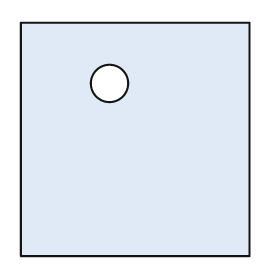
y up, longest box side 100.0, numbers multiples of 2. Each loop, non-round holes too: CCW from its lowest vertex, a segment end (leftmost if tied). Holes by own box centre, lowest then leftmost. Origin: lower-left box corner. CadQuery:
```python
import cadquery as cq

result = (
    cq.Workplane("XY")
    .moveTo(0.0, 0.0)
    .lineTo(98.0, 0.0)
    .lineTo(98.0, 100.0)
    .lineTo(0.0, 100.0)
    .close()
    .moveTo(38.0, 74.0)
    .circle(8.0)
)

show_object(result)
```